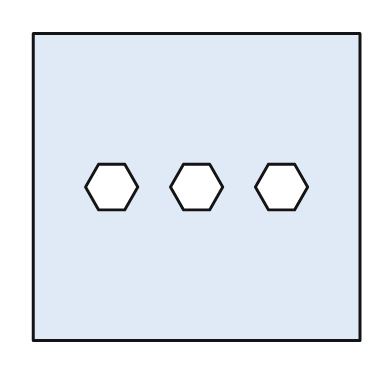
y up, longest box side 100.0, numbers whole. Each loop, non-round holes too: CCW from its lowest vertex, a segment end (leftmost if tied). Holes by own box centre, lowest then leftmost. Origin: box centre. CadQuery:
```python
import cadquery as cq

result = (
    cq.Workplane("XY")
    .moveTo(-50.0, -47.0)
    .lineTo(50.0, -47.0)
    .lineTo(50.0, 47.0)
    .lineTo(-50.0, 47.0)
    .close()
    .moveTo(-30.0, -7.0)
    .lineTo(-22.0, -7.0)
    .lineTo(-18.0, 0.0)
    .lineTo(-22.0, 7.0)
    .lineTo(-30.0, 7.0)
    .lineTo(-34.0, 0.0)
    .close()
    .moveTo(-4.0, -7.0)
    .lineTo(4.0, -7.0)
    .lineTo(8.0, 0.0)
    .lineTo(4.0, 7.0)
    .lineTo(-4.0, 7.0)
    .lineTo(-8.0, 0.0)
    .close()
    .moveTo(22.0, -7.0)
    .lineTo(30.0, -7.0)
    .lineTo(34.0, 0.0)
    .lineTo(30.0, 7.0)
    .lineTo(22.0, 7.0)
    .lineTo(18.0, 0.0)
    .close()
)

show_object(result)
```